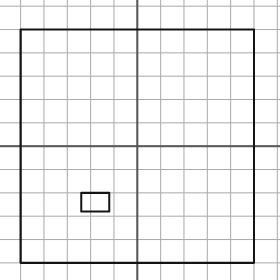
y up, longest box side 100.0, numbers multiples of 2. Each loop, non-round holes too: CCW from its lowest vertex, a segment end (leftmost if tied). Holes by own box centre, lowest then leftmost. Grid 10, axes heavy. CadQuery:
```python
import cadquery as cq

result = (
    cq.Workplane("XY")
    .moveTo(-50.0, -50.0)
    .lineTo(50.0, -50.0)
    .lineTo(50.0, 50.0)
    .lineTo(-50.0, 50.0)
    .close()
    .moveTo(-24.0, -28.0)
    .lineTo(-12.0, -28.0)
    .lineTo(-12.0, -20.0)
    .lineTo(-24.0, -20.0)
    .close()
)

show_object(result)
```